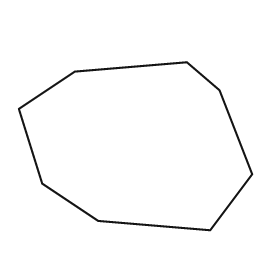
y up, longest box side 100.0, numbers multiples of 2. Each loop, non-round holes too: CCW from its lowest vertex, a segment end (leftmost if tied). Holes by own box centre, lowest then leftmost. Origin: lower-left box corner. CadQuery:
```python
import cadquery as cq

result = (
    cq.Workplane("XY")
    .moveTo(82.0, 0.0)
    .lineTo(100.0, 24.0)
    .lineTo(86.0, 60.0)
    .lineTo(72.0, 72.0)
    .lineTo(24.0, 68.0)
    .lineTo(0.0, 52.0)
    .lineTo(10.0, 20.0)
    .lineTo(34.0, 4.0)
    .close()
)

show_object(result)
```